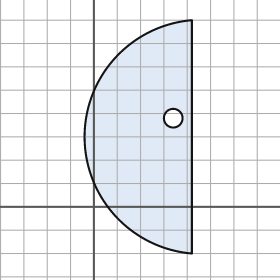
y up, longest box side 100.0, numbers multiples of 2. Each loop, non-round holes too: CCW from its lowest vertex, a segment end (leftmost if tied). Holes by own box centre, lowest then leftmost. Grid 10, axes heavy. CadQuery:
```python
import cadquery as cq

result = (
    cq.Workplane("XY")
    .moveTo(42.0, -20.0)
    .lineTo(42.0, 80.0)
    .threePointArc((-4.0, 30.0), (42.0, -20.0))
    .close()
    .moveTo(34.0, 38.0)
    .circle(4.0)
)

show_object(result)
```